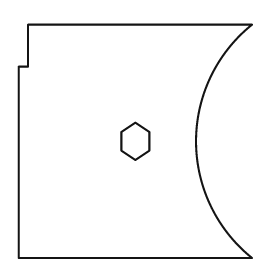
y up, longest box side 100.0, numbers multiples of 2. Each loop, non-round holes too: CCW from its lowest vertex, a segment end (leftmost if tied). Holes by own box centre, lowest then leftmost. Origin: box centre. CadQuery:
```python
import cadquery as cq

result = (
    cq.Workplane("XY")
    .moveTo(-50.0, -50.0)
    .lineTo(50.0, -50.0)
    .threePointArc((26.0, 0.0), (50.0, 50.0))
    .lineTo(-46.0, 50.0)
    .lineTo(-46.0, 32.0)
    .lineTo(-50.0, 32.0)
    .close()
    .moveTo(0.0, -8.0)
    .lineTo(6.0, -4.0)
    .lineTo(6.0, 4.0)
    .lineTo(0.0, 8.0)
    .lineTo(-6.0, 4.0)
    .lineTo(-6.0, -4.0)
    .close()
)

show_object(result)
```